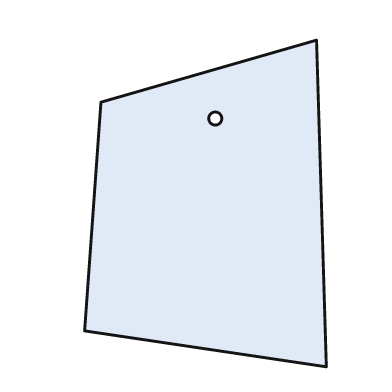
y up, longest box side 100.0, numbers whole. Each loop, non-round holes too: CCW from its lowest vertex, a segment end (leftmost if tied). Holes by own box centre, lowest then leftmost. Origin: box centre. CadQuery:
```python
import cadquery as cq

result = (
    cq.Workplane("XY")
    .moveTo(37.0, -50.0)
    .lineTo(34.0, 50.0)
    .lineTo(-32.0, 31.0)
    .lineTo(-37.0, -39.0)
    .close()
    .moveTo(3.0, 26.0)
    .circle(2.0)
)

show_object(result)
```